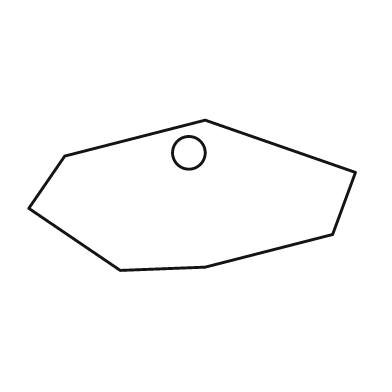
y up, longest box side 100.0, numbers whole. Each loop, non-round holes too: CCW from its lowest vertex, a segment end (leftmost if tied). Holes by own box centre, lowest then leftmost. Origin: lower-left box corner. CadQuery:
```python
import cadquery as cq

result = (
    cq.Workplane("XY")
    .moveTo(28.0, 0.0)
    .lineTo(54.0, 1.0)
    .lineTo(93.0, 11.0)
    .lineTo(100.0, 30.0)
    .lineTo(54.0, 46.0)
    .lineTo(11.0, 35.0)
    .lineTo(0.0, 19.0)
    .close()
    .moveTo(49.0, 36.0)
    .circle(5.0)
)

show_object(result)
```